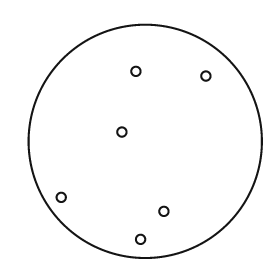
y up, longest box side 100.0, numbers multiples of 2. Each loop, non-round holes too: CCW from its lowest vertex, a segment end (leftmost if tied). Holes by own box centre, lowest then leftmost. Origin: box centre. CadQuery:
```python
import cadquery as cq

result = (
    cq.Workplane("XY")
    .moveTo(0.0, 0.0)
    .circle(50.0)
    .moveTo(-2.0, -42.0)
    .circle(2.0)
    .moveTo(8.0, -30.0)
    .circle(2.0)
    .moveTo(-36.0, -24.0)
    .circle(2.0)
    .moveTo(-10.0, 4.0)
    .circle(2.0)
    .moveTo(26.0, 28.0)
    .circle(2.0)
    .moveTo(-4.0, 30.0)
    .circle(2.0)
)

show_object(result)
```